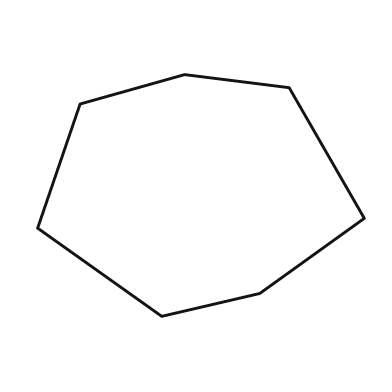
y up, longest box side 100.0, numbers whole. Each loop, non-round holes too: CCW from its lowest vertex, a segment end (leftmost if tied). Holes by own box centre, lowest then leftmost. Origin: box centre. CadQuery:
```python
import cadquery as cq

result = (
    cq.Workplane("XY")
    .moveTo(-12.0, -37.0)
    .lineTo(18.0, -30.0)
    .lineTo(50.0, -7.0)
    .lineTo(27.0, 33.0)
    .lineTo(-5.0, 37.0)
    .lineTo(-37.0, 28.0)
    .lineTo(-50.0, -10.0)
    .close()
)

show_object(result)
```